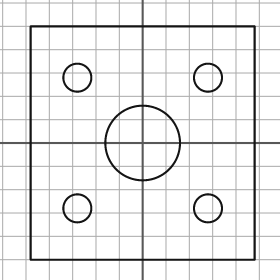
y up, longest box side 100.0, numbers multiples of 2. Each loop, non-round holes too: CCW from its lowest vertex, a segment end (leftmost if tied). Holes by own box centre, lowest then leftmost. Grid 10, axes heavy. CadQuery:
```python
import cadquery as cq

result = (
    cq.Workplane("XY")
    .moveTo(-48.0, -50.0)
    .lineTo(48.0, -50.0)
    .lineTo(48.0, 50.0)
    .lineTo(-48.0, 50.0)
    .close()
    .moveTo(-28.0, -28.0)
    .circle(6.0)
    .moveTo(28.0, -28.0)
    .circle(6.0)
    .moveTo(0.0, 0.0)
    .circle(16.0)
    .moveTo(-28.0, 28.0)
    .circle(6.0)
    .moveTo(28.0, 28.0)
    .circle(6.0)
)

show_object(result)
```